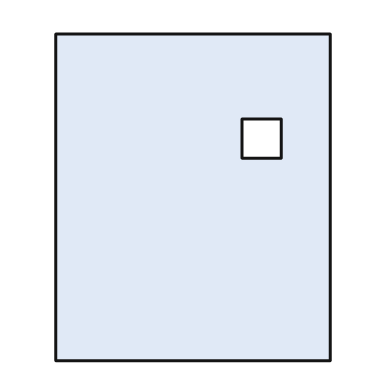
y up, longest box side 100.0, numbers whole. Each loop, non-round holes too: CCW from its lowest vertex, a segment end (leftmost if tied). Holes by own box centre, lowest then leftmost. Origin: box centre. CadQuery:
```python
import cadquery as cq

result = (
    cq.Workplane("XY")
    .moveTo(-42.0, -50.0)
    .lineTo(42.0, -50.0)
    .lineTo(42.0, 50.0)
    .lineTo(-42.0, 50.0)
    .close()
    .moveTo(15.0, 12.0)
    .lineTo(27.0, 12.0)
    .lineTo(27.0, 24.0)
    .lineTo(15.0, 24.0)
    .close()
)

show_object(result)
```